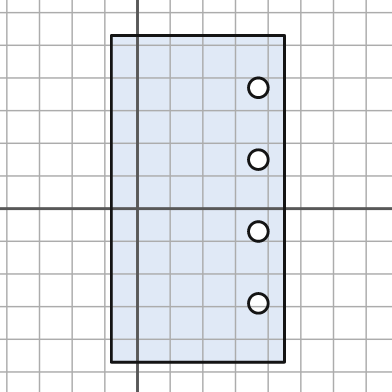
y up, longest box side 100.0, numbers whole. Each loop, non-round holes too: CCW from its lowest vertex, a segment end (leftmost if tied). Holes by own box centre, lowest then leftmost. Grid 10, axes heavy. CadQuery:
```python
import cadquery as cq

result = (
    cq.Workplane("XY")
    .moveTo(-8.0, -47.0)
    .lineTo(45.0, -47.0)
    .lineTo(45.0, 53.0)
    .lineTo(-8.0, 53.0)
    .close()
    .moveTo(37.0, -29.0)
    .circle(3.0)
    .moveTo(37.0, -7.0)
    .circle(3.0)
    .moveTo(37.0, 15.0)
    .circle(3.0)
    .moveTo(37.0, 37.0)
    .circle(3.0)
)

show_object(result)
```